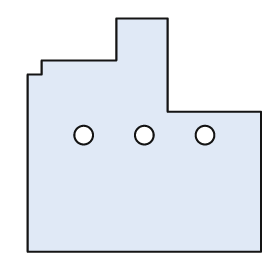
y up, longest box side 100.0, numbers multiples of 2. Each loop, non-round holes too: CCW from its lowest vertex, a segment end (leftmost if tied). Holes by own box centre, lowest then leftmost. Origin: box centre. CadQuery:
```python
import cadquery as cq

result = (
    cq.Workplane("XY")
    .moveTo(-50.0, -50.0)
    .lineTo(50.0, -50.0)
    .lineTo(50.0, 10.0)
    .lineTo(10.0, 10.0)
    .lineTo(10.0, 50.0)
    .lineTo(-12.0, 50.0)
    .lineTo(-12.0, 32.0)
    .lineTo(-44.0, 32.0)
    .lineTo(-44.0, 26.0)
    .lineTo(-50.0, 26.0)
    .close()
    .moveTo(-26.0, 0.0)
    .circle(4.0)
    .moveTo(0.0, 0.0)
    .circle(4.0)
    .moveTo(26.0, 0.0)
    .circle(4.0)
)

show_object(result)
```